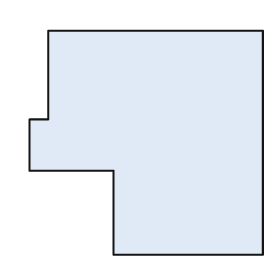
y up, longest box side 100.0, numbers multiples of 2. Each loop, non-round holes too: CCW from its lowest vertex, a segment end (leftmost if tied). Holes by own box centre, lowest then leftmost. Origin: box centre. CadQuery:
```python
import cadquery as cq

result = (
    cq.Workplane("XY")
    .moveTo(-14.0, -48.0)
    .lineTo(50.0, -48.0)
    .lineTo(50.0, 48.0)
    .lineTo(-42.0, 48.0)
    .lineTo(-42.0, 10.0)
    .lineTo(-50.0, 10.0)
    .lineTo(-50.0, -12.0)
    .lineTo(-14.0, -12.0)
    .close()
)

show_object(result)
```